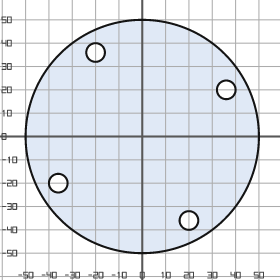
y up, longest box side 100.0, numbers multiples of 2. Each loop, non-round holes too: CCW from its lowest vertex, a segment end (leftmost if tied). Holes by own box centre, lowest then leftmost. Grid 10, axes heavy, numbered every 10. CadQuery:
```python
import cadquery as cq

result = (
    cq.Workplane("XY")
    .moveTo(0.0, 0.0)
    .circle(50.0)
    .moveTo(20.0, -36.0)
    .circle(4.0)
    .moveTo(-36.0, -20.0)
    .circle(4.0)
    .moveTo(36.0, 20.0)
    .circle(4.0)
    .moveTo(-20.0, 36.0)
    .circle(4.0)
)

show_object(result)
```